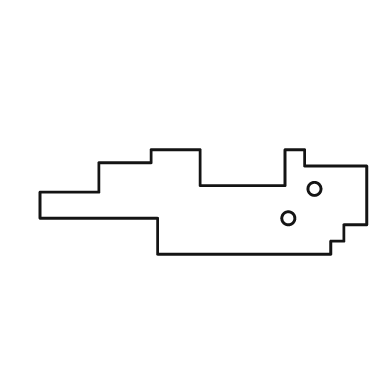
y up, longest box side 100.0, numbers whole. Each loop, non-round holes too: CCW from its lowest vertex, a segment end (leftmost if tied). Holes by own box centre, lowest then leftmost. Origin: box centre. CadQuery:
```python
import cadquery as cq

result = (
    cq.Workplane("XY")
    .moveTo(-14.0, -16.0)
    .lineTo(39.0, -16.0)
    .lineTo(39.0, -12.0)
    .lineTo(43.0, -12.0)
    .lineTo(43.0, -7.0)
    .lineTo(50.0, -7.0)
    .lineTo(50.0, 11.0)
    .lineTo(31.0, 11.0)
    .lineTo(31.0, 16.0)
    .lineTo(25.0, 16.0)
    .lineTo(25.0, 5.0)
    .lineTo(-1.0, 5.0)
    .lineTo(-1.0, 16.0)
    .lineTo(-16.0, 16.0)
    .lineTo(-16.0, 12.0)
    .lineTo(-32.0, 12.0)
    .lineTo(-32.0, 3.0)
    .lineTo(-50.0, 3.0)
    .lineTo(-50.0, -5.0)
    .lineTo(-14.0, -5.0)
    .close()
    .moveTo(26.0, -5.0)
    .circle(2.0)
    .moveTo(34.0, 4.0)
    .circle(2.0)
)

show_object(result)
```